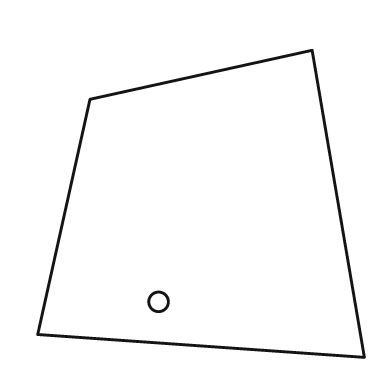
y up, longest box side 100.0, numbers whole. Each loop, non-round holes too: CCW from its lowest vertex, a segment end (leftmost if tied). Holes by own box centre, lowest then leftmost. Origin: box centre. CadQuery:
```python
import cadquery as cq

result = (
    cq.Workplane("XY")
    .moveTo(50.0, -47.0)
    .lineTo(34.0, 47.0)
    .lineTo(-34.0, 32.0)
    .lineTo(-50.0, -40.0)
    .close()
    .moveTo(-13.0, -30.0)
    .circle(3.0)
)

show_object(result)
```